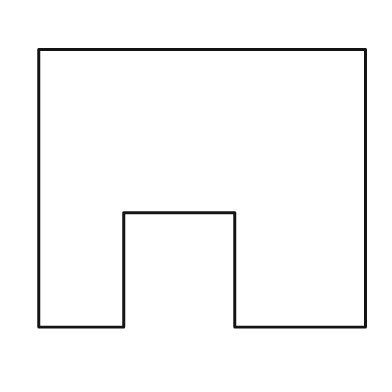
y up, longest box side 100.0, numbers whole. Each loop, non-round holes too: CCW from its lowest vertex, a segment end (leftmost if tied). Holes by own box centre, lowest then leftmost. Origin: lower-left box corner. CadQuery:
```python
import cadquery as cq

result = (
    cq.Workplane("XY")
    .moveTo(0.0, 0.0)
    .lineTo(26.0, 0.0)
    .lineTo(26.0, 35.0)
    .lineTo(60.0, 35.0)
    .lineTo(60.0, 0.0)
    .lineTo(100.0, 0.0)
    .lineTo(100.0, 85.0)
    .lineTo(0.0, 85.0)
    .close()
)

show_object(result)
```